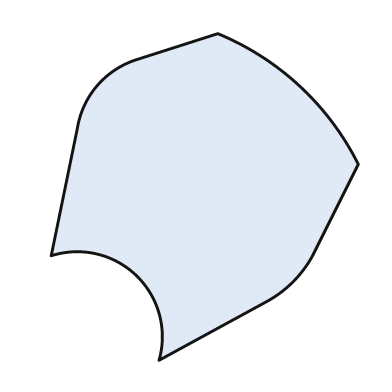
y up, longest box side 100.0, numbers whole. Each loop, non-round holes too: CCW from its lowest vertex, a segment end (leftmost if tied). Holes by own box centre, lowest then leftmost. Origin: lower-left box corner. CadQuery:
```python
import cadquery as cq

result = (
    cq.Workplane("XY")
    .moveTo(33.0, 0.0)
    .lineTo(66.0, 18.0)
    .threePointArc((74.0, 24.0), (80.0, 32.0))
    .lineTo(94.0, 60.0)
    .threePointArc((76.0, 84.0), (51.0, 100.0))
    .lineTo(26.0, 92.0)
    .threePointArc((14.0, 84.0), (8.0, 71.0))
    .lineTo(0.0, 32.0)
    .threePointArc((26.0, 26.0), (33.0, 0.0))
    .close()
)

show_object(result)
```